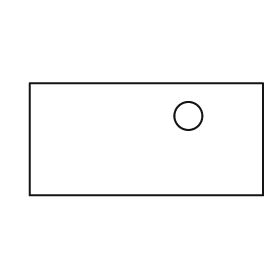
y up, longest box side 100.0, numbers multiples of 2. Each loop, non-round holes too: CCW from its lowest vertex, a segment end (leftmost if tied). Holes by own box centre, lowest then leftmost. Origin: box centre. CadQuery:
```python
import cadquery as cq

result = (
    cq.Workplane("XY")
    .moveTo(-50.0, -24.0)
    .lineTo(50.0, -24.0)
    .lineTo(50.0, 24.0)
    .lineTo(-50.0, 24.0)
    .close()
    .moveTo(18.0, 10.0)
    .circle(6.0)
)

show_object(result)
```